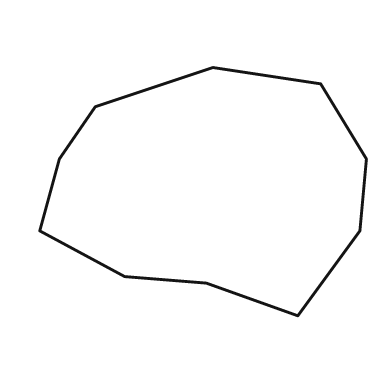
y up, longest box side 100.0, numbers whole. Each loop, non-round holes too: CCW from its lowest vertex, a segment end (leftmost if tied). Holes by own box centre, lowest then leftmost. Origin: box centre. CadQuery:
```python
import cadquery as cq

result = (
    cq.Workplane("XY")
    .moveTo(29.0, -38.0)
    .lineTo(48.0, -12.0)
    .lineTo(50.0, 10.0)
    .lineTo(36.0, 33.0)
    .lineTo(3.0, 38.0)
    .lineTo(-33.0, 26.0)
    .lineTo(-44.0, 10.0)
    .lineTo(-50.0, -12.0)
    .lineTo(-24.0, -26.0)
    .lineTo(1.0, -28.0)
    .close()
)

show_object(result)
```